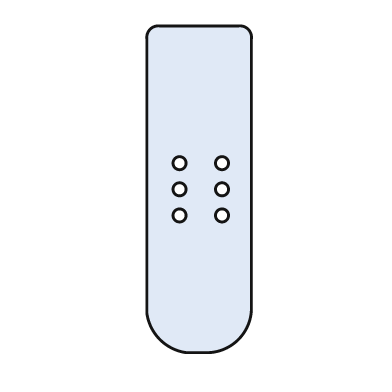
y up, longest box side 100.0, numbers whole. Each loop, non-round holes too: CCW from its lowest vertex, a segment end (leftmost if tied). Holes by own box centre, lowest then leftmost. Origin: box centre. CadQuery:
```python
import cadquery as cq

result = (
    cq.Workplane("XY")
    .moveTo(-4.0, -50.0)
    .lineTo(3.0, -50.0)
    .threePointArc((12.0, -46.0), (16.0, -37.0))
    .lineTo(16.0, 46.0)
    .threePointArc((15.0, 49.0), (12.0, 50.0))
    .lineTo(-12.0, 50.0)
    .threePointArc((-15.0, 49.0), (-16.0, 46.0))
    .lineTo(-16.0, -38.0)
    .threePointArc((-12.0, -46.0), (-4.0, -50.0))
    .close()
    .moveTo(-6.0, -8.0)
    .circle(2.0)
    .moveTo(7.0, -8.0)
    .circle(2.0)
    .moveTo(-6.0, 0.0)
    .circle(2.0)
    .moveTo(7.0, 0.0)
    .circle(2.0)
    .moveTo(-6.0, 8.0)
    .circle(2.0)
    .moveTo(7.0, 8.0)
    .circle(2.0)
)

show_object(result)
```